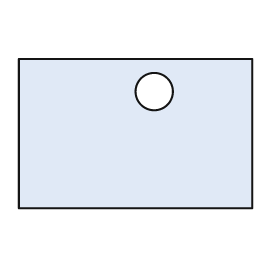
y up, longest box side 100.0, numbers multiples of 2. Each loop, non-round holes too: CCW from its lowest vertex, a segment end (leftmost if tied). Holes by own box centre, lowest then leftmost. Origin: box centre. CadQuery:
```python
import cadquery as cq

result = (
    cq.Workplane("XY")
    .moveTo(-50.0, -32.0)
    .lineTo(50.0, -32.0)
    .lineTo(50.0, 32.0)
    .lineTo(-50.0, 32.0)
    .close()
    .moveTo(8.0, 18.0)
    .circle(8.0)
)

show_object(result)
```